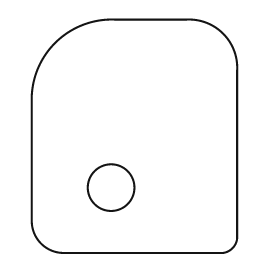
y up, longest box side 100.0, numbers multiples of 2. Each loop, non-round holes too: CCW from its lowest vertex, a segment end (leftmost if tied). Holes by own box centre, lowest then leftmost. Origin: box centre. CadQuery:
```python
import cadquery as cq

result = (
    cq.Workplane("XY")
    .moveTo(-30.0, -50.0)
    .lineTo(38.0, -50.0)
    .threePointArc((42.0, -48.0), (44.0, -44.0))
    .lineTo(44.0, 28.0)
    .threePointArc((38.0, 44.0), (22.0, 50.0))
    .lineTo(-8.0, 50.0)
    .threePointArc((-34.0, 40.0), (-44.0, 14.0))
    .lineTo(-44.0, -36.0)
    .threePointArc((-40.0, -46.0), (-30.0, -50.0))
    .close()
    .moveTo(-10.0, -22.0)
    .circle(10.0)
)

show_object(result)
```